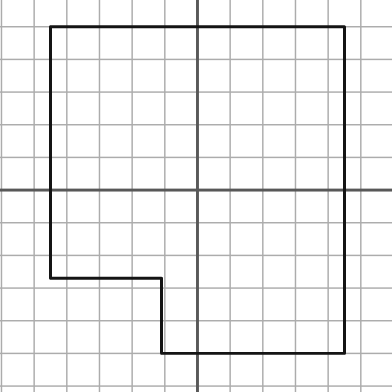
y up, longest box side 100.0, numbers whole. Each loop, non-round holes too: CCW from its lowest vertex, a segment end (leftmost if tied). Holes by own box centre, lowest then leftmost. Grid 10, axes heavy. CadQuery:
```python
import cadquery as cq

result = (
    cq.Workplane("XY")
    .moveTo(-11.0, -50.0)
    .lineTo(45.0, -50.0)
    .lineTo(45.0, 50.0)
    .lineTo(-45.0, 50.0)
    .lineTo(-45.0, -27.0)
    .lineTo(-11.0, -27.0)
    .close()
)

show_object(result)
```